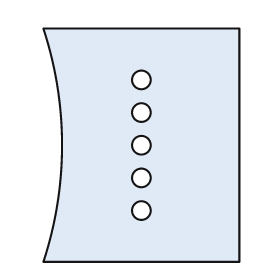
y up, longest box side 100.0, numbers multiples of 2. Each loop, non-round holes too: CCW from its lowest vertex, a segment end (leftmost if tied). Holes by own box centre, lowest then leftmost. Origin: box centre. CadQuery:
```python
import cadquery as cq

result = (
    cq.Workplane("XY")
    .moveTo(-42.0, -50.0)
    .lineTo(42.0, -50.0)
    .lineTo(42.0, 50.0)
    .lineTo(-42.0, 50.0)
    .threePointArc((-34.0, 0.0), (-42.0, -50.0))
    .close()
    .moveTo(0.0, -28.0)
    .circle(4.0)
    .moveTo(0.0, -14.0)
    .circle(4.0)
    .moveTo(0.0, 0.0)
    .circle(4.0)
    .moveTo(0.0, 14.0)
    .circle(4.0)
    .moveTo(0.0, 28.0)
    .circle(4.0)
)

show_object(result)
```